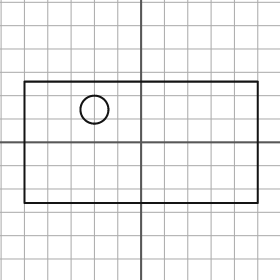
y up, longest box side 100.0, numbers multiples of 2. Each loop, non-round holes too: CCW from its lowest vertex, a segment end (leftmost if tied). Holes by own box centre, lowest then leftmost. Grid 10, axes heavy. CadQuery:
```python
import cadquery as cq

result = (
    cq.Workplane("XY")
    .moveTo(-50.0, -26.0)
    .lineTo(50.0, -26.0)
    .lineTo(50.0, 26.0)
    .lineTo(-50.0, 26.0)
    .close()
    .moveTo(-20.0, 14.0)
    .circle(6.0)
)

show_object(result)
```